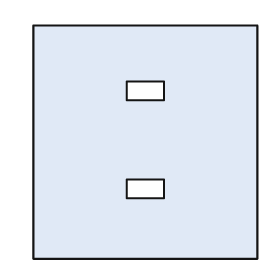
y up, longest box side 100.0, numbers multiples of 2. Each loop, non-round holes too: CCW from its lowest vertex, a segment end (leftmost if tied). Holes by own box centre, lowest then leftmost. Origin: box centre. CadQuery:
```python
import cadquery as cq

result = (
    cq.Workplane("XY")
    .moveTo(-48.0, -50.0)
    .lineTo(48.0, -50.0)
    .lineTo(48.0, 50.0)
    .lineTo(-48.0, 50.0)
    .close()
    .moveTo(-8.0, -24.0)
    .lineTo(8.0, -24.0)
    .lineTo(8.0, -16.0)
    .lineTo(-8.0, -16.0)
    .close()
    .moveTo(-8.0, 18.0)
    .lineTo(8.0, 18.0)
    .lineTo(8.0, 26.0)
    .lineTo(-8.0, 26.0)
    .close()
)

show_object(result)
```